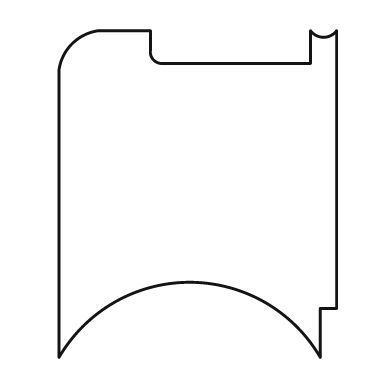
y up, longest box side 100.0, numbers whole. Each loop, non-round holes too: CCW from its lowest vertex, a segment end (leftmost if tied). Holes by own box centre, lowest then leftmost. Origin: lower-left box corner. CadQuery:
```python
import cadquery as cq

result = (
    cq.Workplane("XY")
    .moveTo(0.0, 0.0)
    .threePointArc((40.0, 23.0), (80.0, 0.0))
    .lineTo(80.0, 15.0)
    .lineTo(85.0, 15.0)
    .lineTo(85.0, 100.0)
    .threePointArc((81.0, 98.0), (77.0, 100.0))
    .lineTo(77.0, 90.0)
    .lineTo(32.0, 90.0)
    .threePointArc((29.0, 91.0), (28.0, 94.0))
    .lineTo(28.0, 100.0)
    .lineTo(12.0, 100.0)
    .threePointArc((4.0, 96.0), (0.0, 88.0))
    .close()
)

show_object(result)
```